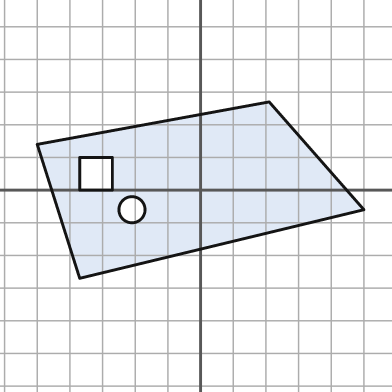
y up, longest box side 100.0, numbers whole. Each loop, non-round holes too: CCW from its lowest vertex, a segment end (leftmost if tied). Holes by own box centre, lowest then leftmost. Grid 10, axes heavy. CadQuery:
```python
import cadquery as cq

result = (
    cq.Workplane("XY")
    .moveTo(-37.0, -27.0)
    .lineTo(50.0, -6.0)
    .lineTo(21.0, 27.0)
    .lineTo(-50.0, 14.0)
    .close()
    .moveTo(-21.0, -6.0)
    .circle(4.0)
    .moveTo(-37.0, 0.0)
    .lineTo(-27.0, 0.0)
    .lineTo(-27.0, 10.0)
    .lineTo(-37.0, 10.0)
    .close()
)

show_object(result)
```